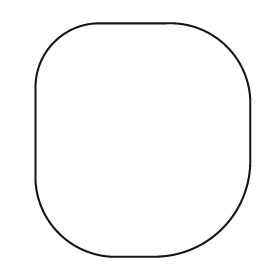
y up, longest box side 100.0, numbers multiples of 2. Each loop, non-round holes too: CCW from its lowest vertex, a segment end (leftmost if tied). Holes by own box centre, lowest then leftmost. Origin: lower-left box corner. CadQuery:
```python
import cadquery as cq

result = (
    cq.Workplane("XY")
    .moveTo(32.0, 0.0)
    .lineTo(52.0, 0.0)
    .threePointArc((80.0, 12.0), (92.0, 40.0))
    .lineTo(92.0, 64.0)
    .threePointArc((82.0, 90.0), (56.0, 100.0))
    .lineTo(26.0, 100.0)
    .threePointArc((8.0, 92.0), (0.0, 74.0))
    .lineTo(0.0, 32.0)
    .threePointArc((10.0, 10.0), (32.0, 0.0))
    .close()
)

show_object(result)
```